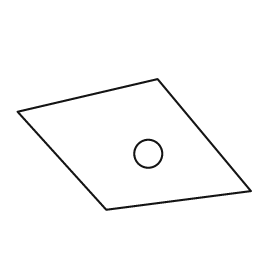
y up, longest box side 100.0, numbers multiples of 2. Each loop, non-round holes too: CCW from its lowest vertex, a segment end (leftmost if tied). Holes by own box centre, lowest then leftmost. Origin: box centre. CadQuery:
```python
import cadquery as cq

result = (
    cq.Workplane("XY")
    .moveTo(-12.0, -28.0)
    .lineTo(50.0, -20.0)
    .lineTo(10.0, 28.0)
    .lineTo(-50.0, 14.0)
    .close()
    .moveTo(6.0, -4.0)
    .circle(6.0)
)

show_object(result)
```